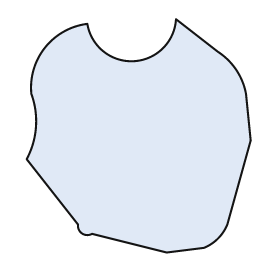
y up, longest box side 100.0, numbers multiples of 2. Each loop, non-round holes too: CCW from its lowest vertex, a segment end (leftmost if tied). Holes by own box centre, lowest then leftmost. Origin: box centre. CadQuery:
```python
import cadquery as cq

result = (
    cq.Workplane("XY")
    .moveTo(12.0, -50.0)
    .lineTo(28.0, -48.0)
    .threePointArc((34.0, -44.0), (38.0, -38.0))
    .lineTo(48.0, -2.0)
    .lineTo(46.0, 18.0)
    .threePointArc((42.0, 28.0), (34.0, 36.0))
    .lineTo(16.0, 50.0)
    .threePointArc((-2.0, 32.0), (-22.0, 48.0))
    .threePointArc((-40.0, 38.0), (-46.0, 18.0))
    .threePointArc((-44.0, 4.0), (-48.0, -10.0))
    .lineTo(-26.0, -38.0)
    .threePointArc((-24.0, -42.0), (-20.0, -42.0))
    .close()
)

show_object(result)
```